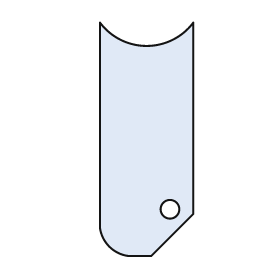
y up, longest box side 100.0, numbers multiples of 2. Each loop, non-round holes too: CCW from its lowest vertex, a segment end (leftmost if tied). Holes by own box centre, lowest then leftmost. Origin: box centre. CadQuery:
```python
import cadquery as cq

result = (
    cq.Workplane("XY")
    .moveTo(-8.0, -50.0)
    .lineTo(2.0, -50.0)
    .lineTo(20.0, -32.0)
    .lineTo(20.0, 50.0)
    .threePointArc((0.0, 40.0), (-20.0, 50.0))
    .lineTo(-20.0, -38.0)
    .threePointArc((-16.0, -46.0), (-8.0, -50.0))
    .close()
    .moveTo(10.0, -30.0)
    .circle(4.0)
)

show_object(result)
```